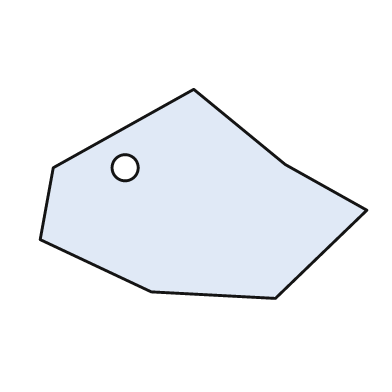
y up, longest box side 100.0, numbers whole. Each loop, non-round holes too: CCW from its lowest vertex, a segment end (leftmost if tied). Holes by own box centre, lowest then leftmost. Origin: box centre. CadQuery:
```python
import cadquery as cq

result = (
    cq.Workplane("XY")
    .moveTo(22.0, -32.0)
    .lineTo(50.0, -5.0)
    .lineTo(25.0, 9.0)
    .lineTo(-3.0, 32.0)
    .lineTo(-46.0, 8.0)
    .lineTo(-50.0, -14.0)
    .lineTo(-16.0, -30.0)
    .close()
    .moveTo(-24.0, 8.0)
    .circle(4.0)
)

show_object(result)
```